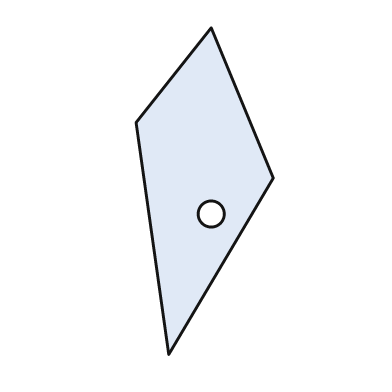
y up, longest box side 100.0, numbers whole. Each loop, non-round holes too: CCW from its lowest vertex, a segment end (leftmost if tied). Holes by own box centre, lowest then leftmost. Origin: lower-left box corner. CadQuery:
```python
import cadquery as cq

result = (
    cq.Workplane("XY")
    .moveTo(10.0, 0.0)
    .lineTo(42.0, 54.0)
    .lineTo(23.0, 100.0)
    .lineTo(0.0, 71.0)
    .close()
    .moveTo(23.0, 43.0)
    .circle(4.0)
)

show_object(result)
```